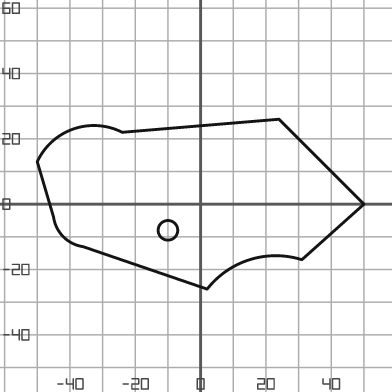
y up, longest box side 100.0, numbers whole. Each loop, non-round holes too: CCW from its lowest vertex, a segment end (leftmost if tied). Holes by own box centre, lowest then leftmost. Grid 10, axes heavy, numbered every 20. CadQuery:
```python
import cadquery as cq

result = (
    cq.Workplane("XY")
    .moveTo(2.0, -26.0)
    .threePointArc((15.0, -17.0), (31.0, -17.0))
    .lineTo(50.0, 0.0)
    .lineTo(24.0, 26.0)
    .lineTo(-24.0, 22.0)
    .threePointArc((-39.0, 23.0), (-50.0, 13.0))
    .lineTo(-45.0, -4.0)
    .threePointArc((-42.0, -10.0), (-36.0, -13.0))
    .close()
    .moveTo(-10.0, -8.0)
    .circle(3.0)
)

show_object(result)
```